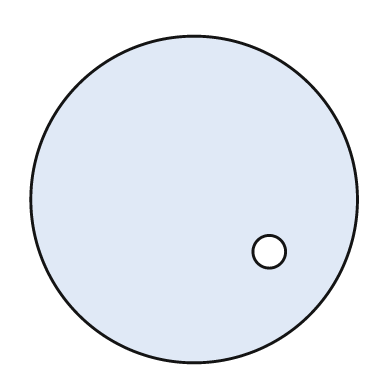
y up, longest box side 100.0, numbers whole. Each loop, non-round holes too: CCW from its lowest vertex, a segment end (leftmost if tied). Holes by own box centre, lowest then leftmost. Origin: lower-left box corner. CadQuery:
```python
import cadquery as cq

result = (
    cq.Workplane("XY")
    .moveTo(50.0, 50.0)
    .circle(50.0)
    .moveTo(73.0, 34.0)
    .circle(5.0)
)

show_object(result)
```